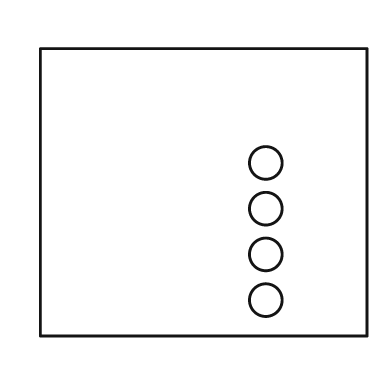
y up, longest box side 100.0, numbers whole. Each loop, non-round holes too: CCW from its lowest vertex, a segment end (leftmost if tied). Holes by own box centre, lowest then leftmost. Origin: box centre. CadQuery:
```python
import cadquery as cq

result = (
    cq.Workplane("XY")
    .moveTo(-50.0, -44.0)
    .lineTo(50.0, -44.0)
    .lineTo(50.0, 44.0)
    .lineTo(-50.0, 44.0)
    .close()
    .moveTo(19.0, -33.0)
    .circle(5.0)
    .moveTo(19.0, -19.0)
    .circle(5.0)
    .moveTo(19.0, -5.0)
    .circle(5.0)
    .moveTo(19.0, 9.0)
    .circle(5.0)
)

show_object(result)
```